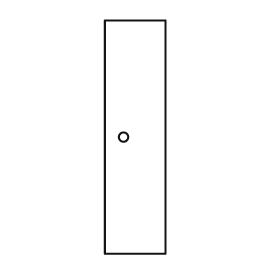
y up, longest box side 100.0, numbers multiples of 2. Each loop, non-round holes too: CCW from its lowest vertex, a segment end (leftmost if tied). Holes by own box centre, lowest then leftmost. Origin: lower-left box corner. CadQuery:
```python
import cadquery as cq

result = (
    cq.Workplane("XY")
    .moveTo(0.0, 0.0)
    .lineTo(26.0, 0.0)
    .lineTo(26.0, 100.0)
    .lineTo(0.0, 100.0)
    .close()
    .moveTo(8.0, 50.0)
    .circle(2.0)
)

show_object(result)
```